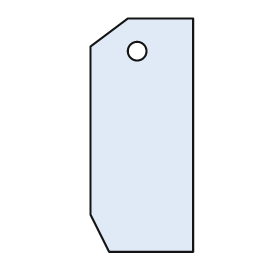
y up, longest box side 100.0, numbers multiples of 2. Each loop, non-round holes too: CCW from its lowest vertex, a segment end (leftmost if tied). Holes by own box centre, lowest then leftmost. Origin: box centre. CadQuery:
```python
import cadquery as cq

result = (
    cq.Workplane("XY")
    .moveTo(-14.0, -50.0)
    .lineTo(22.0, -50.0)
    .lineTo(22.0, 50.0)
    .lineTo(-6.0, 50.0)
    .lineTo(-22.0, 38.0)
    .lineTo(-22.0, -34.0)
    .close()
    .moveTo(-2.0, 36.0)
    .circle(4.0)
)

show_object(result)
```